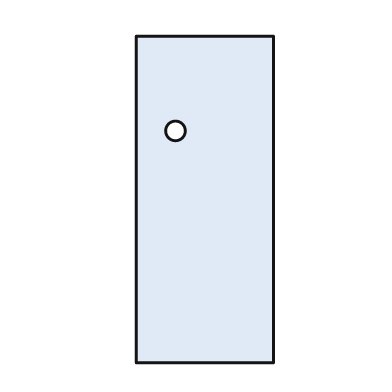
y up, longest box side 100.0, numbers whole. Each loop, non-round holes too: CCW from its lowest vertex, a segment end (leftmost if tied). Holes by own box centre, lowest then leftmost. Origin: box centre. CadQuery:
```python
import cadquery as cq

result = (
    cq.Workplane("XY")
    .moveTo(-21.0, -50.0)
    .lineTo(21.0, -50.0)
    .lineTo(21.0, 50.0)
    .lineTo(-21.0, 50.0)
    .close()
    .moveTo(-9.0, 21.0)
    .circle(3.0)
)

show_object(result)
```